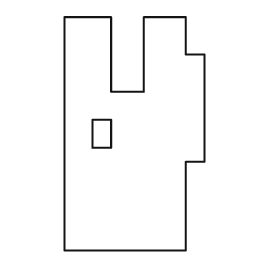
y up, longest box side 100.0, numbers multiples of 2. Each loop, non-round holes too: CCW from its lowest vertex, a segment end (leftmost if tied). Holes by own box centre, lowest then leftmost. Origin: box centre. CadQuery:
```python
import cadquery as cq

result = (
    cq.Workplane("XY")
    .moveTo(-30.0, -50.0)
    .lineTo(22.0, -50.0)
    .lineTo(22.0, -12.0)
    .lineTo(30.0, -12.0)
    .lineTo(30.0, 34.0)
    .lineTo(22.0, 34.0)
    .lineTo(22.0, 50.0)
    .lineTo(4.0, 50.0)
    .lineTo(4.0, 18.0)
    .lineTo(-10.0, 18.0)
    .lineTo(-10.0, 50.0)
    .lineTo(-30.0, 50.0)
    .close()
    .moveTo(-18.0, -6.0)
    .lineTo(-10.0, -6.0)
    .lineTo(-10.0, 6.0)
    .lineTo(-18.0, 6.0)
    .close()
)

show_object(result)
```